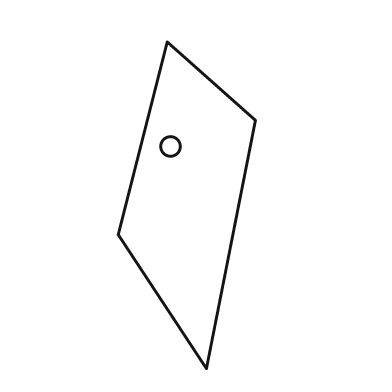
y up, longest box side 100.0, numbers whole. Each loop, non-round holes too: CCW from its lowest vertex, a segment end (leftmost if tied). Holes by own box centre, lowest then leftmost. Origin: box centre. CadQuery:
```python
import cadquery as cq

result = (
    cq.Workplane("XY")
    .moveTo(6.0, -50.0)
    .lineTo(21.0, 26.0)
    .lineTo(-6.0, 50.0)
    .lineTo(-21.0, -9.0)
    .close()
    .moveTo(-5.0, 18.0)
    .circle(3.0)
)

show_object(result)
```